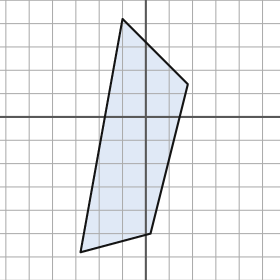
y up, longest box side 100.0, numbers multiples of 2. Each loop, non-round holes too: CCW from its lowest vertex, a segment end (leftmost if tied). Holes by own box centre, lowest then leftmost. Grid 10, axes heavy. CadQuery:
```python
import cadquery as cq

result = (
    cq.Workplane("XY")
    .moveTo(-28.0, -58.0)
    .lineTo(2.0, -50.0)
    .lineTo(18.0, 14.0)
    .lineTo(-10.0, 42.0)
    .close()
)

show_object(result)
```